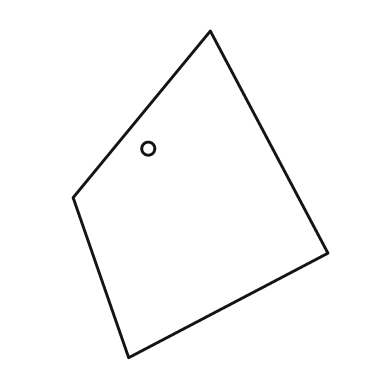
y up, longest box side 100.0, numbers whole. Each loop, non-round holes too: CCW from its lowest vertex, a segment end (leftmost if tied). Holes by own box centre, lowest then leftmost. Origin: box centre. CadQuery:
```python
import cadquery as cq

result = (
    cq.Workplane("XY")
    .moveTo(-22.0, -50.0)
    .lineTo(39.0, -18.0)
    .lineTo(3.0, 50.0)
    .lineTo(-39.0, -1.0)
    .close()
    .moveTo(-16.0, 14.0)
    .circle(2.0)
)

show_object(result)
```